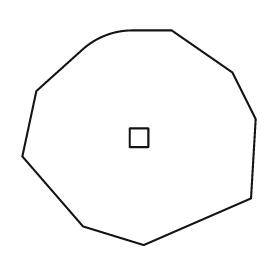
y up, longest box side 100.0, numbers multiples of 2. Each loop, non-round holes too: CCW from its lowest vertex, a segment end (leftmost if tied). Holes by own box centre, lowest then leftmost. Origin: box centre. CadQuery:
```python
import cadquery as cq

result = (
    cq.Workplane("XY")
    .moveTo(2.0, -46.0)
    .lineTo(48.0, -26.0)
    .lineTo(50.0, 8.0)
    .lineTo(40.0, 28.0)
    .lineTo(14.0, 46.0)
    .lineTo(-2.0, 46.0)
    .threePointArc((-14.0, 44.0), (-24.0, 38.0))
    .lineTo(-44.0, 20.0)
    .lineTo(-50.0, -8.0)
    .lineTo(-24.0, -38.0)
    .close()
    .moveTo(-4.0, -4.0)
    .lineTo(4.0, -4.0)
    .lineTo(4.0, 4.0)
    .lineTo(-4.0, 4.0)
    .close()
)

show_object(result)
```